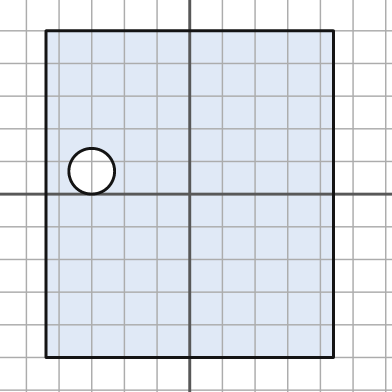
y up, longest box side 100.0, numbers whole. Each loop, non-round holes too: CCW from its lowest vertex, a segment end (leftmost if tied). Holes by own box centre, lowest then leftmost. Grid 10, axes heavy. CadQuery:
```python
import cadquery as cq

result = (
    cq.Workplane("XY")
    .moveTo(-44.0, -50.0)
    .lineTo(44.0, -50.0)
    .lineTo(44.0, 50.0)
    .lineTo(-44.0, 50.0)
    .close()
    .moveTo(-30.0, 7.0)
    .circle(7.0)
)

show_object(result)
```